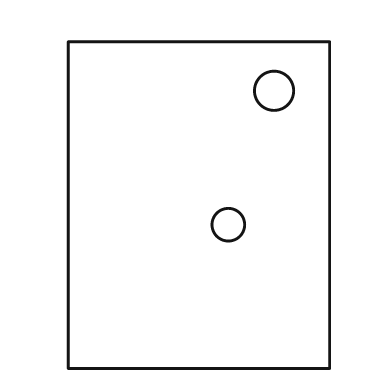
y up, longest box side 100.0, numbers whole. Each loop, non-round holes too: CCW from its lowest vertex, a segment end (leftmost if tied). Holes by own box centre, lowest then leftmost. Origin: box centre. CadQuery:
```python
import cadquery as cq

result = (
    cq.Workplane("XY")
    .moveTo(-40.0, -50.0)
    .lineTo(40.0, -50.0)
    .lineTo(40.0, 50.0)
    .lineTo(-40.0, 50.0)
    .close()
    .moveTo(9.0, -6.0)
    .circle(5.0)
    .moveTo(23.0, 35.0)
    .circle(6.0)
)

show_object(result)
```